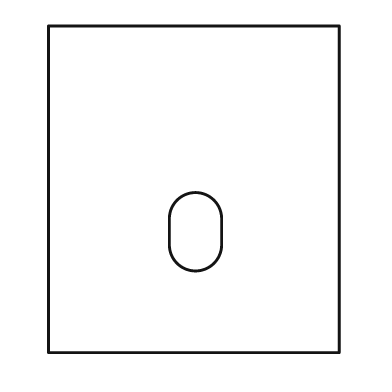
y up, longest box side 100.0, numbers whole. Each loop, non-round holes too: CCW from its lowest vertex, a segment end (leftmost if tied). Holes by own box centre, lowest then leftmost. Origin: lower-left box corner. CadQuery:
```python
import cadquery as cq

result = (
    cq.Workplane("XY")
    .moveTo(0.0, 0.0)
    .lineTo(89.0, 0.0)
    .lineTo(89.0, 100.0)
    .lineTo(0.0, 100.0)
    .close()
    .moveTo(37.0, 33.0)
    .threePointArc((45.0, 25.0), (53.0, 33.0))
    .lineTo(53.0, 41.0)
    .threePointArc((45.0, 49.0), (37.0, 41.0))
    .close()
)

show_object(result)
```